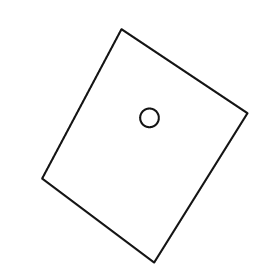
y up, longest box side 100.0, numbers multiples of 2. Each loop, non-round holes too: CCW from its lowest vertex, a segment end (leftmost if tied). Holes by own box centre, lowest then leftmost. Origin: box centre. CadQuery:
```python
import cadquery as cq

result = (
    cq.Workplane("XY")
    .moveTo(4.0, -50.0)
    .lineTo(44.0, 14.0)
    .lineTo(-10.0, 50.0)
    .lineTo(-44.0, -14.0)
    .close()
    .moveTo(2.0, 12.0)
    .circle(4.0)
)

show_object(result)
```